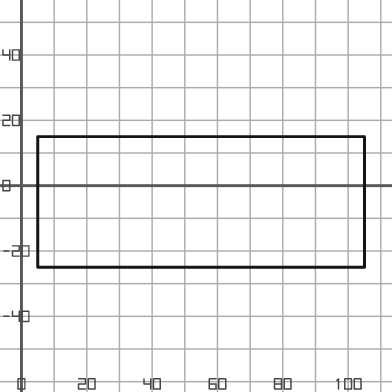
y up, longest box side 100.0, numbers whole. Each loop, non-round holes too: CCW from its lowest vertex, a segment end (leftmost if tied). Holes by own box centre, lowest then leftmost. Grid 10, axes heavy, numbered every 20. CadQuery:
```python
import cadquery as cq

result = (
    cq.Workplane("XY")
    .moveTo(5.0, -25.0)
    .lineTo(105.0, -25.0)
    .lineTo(105.0, 15.0)
    .lineTo(5.0, 15.0)
    .close()
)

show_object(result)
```